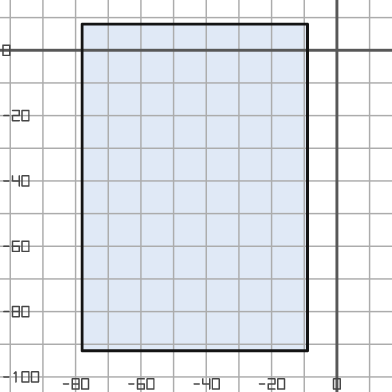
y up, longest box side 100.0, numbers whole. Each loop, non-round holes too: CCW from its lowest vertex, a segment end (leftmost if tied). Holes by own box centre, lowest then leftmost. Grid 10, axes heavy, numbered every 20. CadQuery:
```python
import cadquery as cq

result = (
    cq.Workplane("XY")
    .moveTo(-78.0, -92.0)
    .lineTo(-9.0, -92.0)
    .lineTo(-9.0, 8.0)
    .lineTo(-78.0, 8.0)
    .close()
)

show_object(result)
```